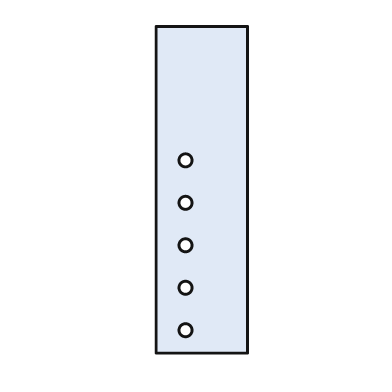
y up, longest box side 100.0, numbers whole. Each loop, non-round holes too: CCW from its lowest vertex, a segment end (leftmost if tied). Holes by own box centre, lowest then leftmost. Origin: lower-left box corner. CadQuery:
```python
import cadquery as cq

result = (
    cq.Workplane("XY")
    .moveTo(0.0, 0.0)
    .lineTo(28.0, 0.0)
    .lineTo(28.0, 100.0)
    .lineTo(0.0, 100.0)
    .close()
    .moveTo(9.0, 7.0)
    .circle(2.0)
    .moveTo(9.0, 20.0)
    .circle(2.0)
    .moveTo(9.0, 33.0)
    .circle(2.0)
    .moveTo(9.0, 46.0)
    .circle(2.0)
    .moveTo(9.0, 59.0)
    .circle(2.0)
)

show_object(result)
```